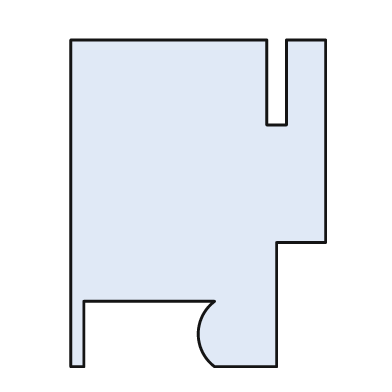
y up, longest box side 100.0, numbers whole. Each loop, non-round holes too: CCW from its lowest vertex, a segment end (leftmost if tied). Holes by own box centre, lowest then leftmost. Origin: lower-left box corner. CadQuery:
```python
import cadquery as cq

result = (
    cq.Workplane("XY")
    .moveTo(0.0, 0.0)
    .lineTo(4.0, 0.0)
    .lineTo(4.0, 20.0)
    .lineTo(44.0, 20.0)
    .threePointArc((39.0, 10.0), (44.0, 0.0))
    .lineTo(63.0, 0.0)
    .lineTo(63.0, 38.0)
    .lineTo(78.0, 38.0)
    .lineTo(78.0, 100.0)
    .lineTo(66.0, 100.0)
    .lineTo(66.0, 74.0)
    .lineTo(60.0, 74.0)
    .lineTo(60.0, 100.0)
    .lineTo(0.0, 100.0)
    .close()
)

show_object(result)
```